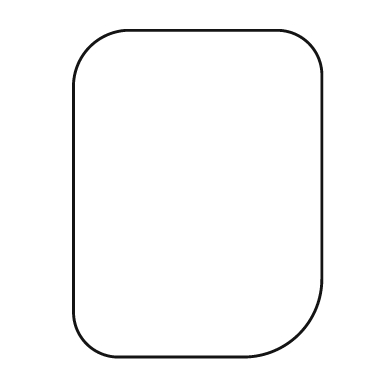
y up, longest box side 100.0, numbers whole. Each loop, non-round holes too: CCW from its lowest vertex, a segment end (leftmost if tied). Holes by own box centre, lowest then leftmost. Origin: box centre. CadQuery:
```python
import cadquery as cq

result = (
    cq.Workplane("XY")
    .moveTo(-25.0, -50.0)
    .lineTo(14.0, -50.0)
    .threePointArc((31.0, -43.0), (38.0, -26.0))
    .lineTo(38.0, 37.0)
    .threePointArc((34.0, 46.0), (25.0, 50.0))
    .lineTo(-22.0, 50.0)
    .threePointArc((-33.0, 45.0), (-38.0, 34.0))
    .lineTo(-38.0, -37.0)
    .threePointArc((-34.0, -46.0), (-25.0, -50.0))
    .close()
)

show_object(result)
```